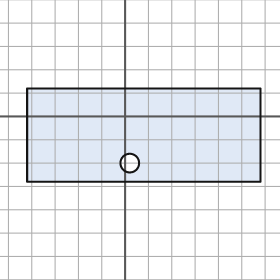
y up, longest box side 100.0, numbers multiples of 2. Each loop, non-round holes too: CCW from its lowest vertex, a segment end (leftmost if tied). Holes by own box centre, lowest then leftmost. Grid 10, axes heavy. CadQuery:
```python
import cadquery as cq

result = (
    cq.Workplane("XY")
    .moveTo(-42.0, -28.0)
    .lineTo(58.0, -28.0)
    .lineTo(58.0, 12.0)
    .lineTo(-42.0, 12.0)
    .close()
    .moveTo(2.0, -20.0)
    .circle(4.0)
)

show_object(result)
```